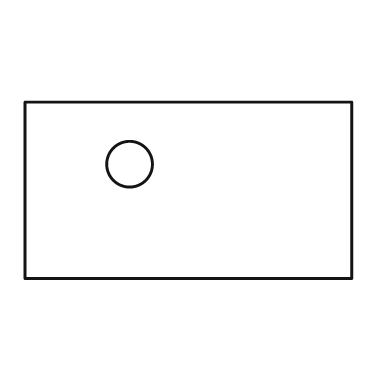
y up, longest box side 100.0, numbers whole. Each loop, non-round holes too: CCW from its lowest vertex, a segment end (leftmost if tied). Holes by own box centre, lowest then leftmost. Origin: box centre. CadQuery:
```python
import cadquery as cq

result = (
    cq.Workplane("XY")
    .moveTo(-50.0, -27.0)
    .lineTo(50.0, -27.0)
    .lineTo(50.0, 27.0)
    .lineTo(-50.0, 27.0)
    .close()
    .moveTo(-18.0, 8.0)
    .circle(7.0)
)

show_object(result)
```